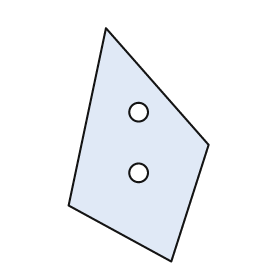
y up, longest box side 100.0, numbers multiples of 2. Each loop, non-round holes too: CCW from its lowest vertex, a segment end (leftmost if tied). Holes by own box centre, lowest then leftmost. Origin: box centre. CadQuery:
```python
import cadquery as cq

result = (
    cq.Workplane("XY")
    .moveTo(14.0, -50.0)
    .lineTo(30.0, 0.0)
    .lineTo(-14.0, 50.0)
    .lineTo(-30.0, -26.0)
    .close()
    .moveTo(0.0, -12.0)
    .circle(4.0)
    .moveTo(0.0, 14.0)
    .circle(4.0)
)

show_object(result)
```